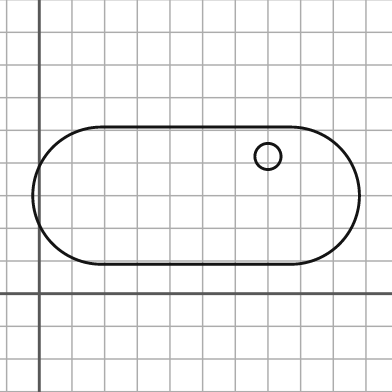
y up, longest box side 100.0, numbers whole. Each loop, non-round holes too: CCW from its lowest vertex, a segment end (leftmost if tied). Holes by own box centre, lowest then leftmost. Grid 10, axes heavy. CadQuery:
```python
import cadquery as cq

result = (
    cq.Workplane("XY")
    .moveTo(19.0, 9.0)
    .lineTo(77.0, 9.0)
    .threePointArc((98.0, 30.0), (77.0, 51.0))
    .lineTo(19.0, 51.0)
    .threePointArc((-2.0, 30.0), (19.0, 9.0))
    .close()
    .moveTo(70.0, 42.0)
    .circle(4.0)
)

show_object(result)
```